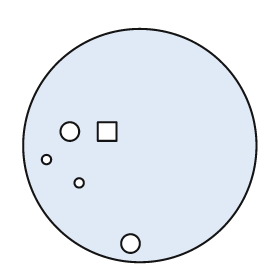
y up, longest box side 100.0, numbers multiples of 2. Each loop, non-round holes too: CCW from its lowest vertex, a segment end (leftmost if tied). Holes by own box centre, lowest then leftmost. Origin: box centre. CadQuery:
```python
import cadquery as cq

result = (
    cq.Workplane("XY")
    .moveTo(0.0, 0.0)
    .circle(50.0)
    .moveTo(-4.0, -42.0)
    .circle(4.0)
    .moveTo(-26.0, -16.0)
    .circle(2.0)
    .moveTo(-40.0, -6.0)
    .circle(2.0)
    .moveTo(-30.0, 6.0)
    .circle(4.0)
    .moveTo(-18.0, 2.0)
    .lineTo(-10.0, 2.0)
    .lineTo(-10.0, 10.0)
    .lineTo(-18.0, 10.0)
    .close()
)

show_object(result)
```